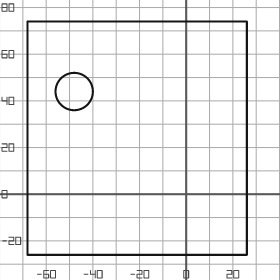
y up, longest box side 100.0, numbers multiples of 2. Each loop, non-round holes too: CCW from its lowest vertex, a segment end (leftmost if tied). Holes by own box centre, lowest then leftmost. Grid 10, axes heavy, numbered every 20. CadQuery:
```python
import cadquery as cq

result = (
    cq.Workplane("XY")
    .moveTo(-68.0, -26.0)
    .lineTo(26.0, -26.0)
    .lineTo(26.0, 74.0)
    .lineTo(-68.0, 74.0)
    .close()
    .moveTo(-48.0, 44.0)
    .circle(8.0)
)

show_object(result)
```